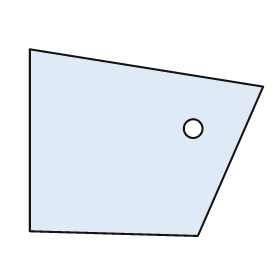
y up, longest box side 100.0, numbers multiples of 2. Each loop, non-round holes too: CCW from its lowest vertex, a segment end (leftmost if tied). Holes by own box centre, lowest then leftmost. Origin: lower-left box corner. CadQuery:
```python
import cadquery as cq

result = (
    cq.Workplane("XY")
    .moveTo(72.0, 0.0)
    .lineTo(100.0, 64.0)
    .lineTo(0.0, 80.0)
    .lineTo(0.0, 2.0)
    .close()
    .moveTo(70.0, 46.0)
    .circle(4.0)
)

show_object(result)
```